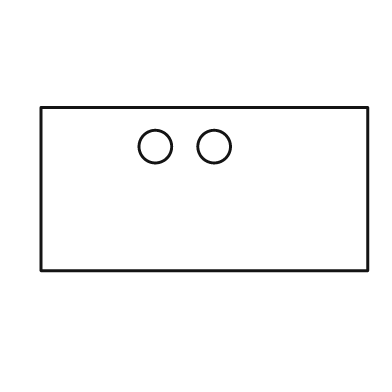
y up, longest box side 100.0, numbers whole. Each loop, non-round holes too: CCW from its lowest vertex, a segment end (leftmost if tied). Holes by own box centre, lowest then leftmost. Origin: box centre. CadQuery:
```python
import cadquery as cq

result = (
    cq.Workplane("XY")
    .moveTo(-50.0, -25.0)
    .lineTo(50.0, -25.0)
    .lineTo(50.0, 25.0)
    .lineTo(-50.0, 25.0)
    .close()
    .moveTo(-15.0, 13.0)
    .circle(5.0)
    .moveTo(3.0, 13.0)
    .circle(5.0)
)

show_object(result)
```